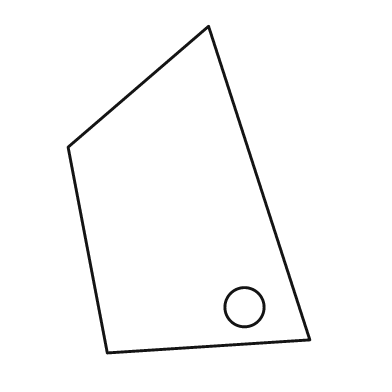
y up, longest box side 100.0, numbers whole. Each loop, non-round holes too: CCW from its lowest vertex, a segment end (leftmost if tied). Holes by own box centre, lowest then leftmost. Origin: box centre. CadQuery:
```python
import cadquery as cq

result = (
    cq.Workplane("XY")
    .moveTo(-25.0, -50.0)
    .lineTo(37.0, -46.0)
    .lineTo(6.0, 50.0)
    .lineTo(-37.0, 13.0)
    .close()
    .moveTo(17.0, -36.0)
    .circle(6.0)
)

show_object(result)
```